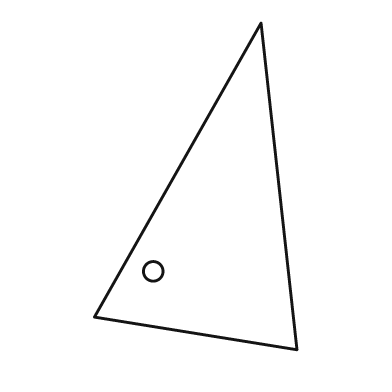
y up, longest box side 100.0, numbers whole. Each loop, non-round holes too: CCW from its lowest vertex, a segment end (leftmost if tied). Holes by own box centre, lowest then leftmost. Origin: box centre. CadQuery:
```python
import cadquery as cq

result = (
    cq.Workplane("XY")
    .moveTo(31.0, -50.0)
    .lineTo(20.0, 50.0)
    .lineTo(-31.0, -40.0)
    .close()
    .moveTo(-13.0, -26.0)
    .circle(3.0)
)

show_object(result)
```